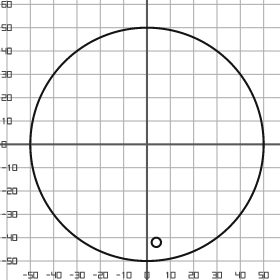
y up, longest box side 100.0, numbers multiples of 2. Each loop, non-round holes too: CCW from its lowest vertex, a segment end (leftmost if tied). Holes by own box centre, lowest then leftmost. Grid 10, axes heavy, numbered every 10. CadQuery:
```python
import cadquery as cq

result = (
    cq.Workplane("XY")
    .moveTo(0.0, 0.0)
    .circle(50.0)
    .moveTo(4.0, -42.0)
    .circle(2.0)
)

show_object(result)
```